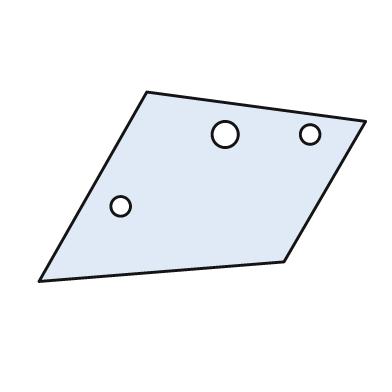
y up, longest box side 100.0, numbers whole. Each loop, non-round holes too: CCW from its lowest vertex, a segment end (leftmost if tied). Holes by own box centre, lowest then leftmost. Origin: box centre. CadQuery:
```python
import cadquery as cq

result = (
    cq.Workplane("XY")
    .moveTo(-50.0, -29.0)
    .lineTo(25.0, -23.0)
    .lineTo(50.0, 20.0)
    .lineTo(-17.0, 29.0)
    .close()
    .moveTo(-25.0, -6.0)
    .circle(3.0)
    .moveTo(7.0, 16.0)
    .circle(4.0)
    .moveTo(33.0, 16.0)
    .circle(3.0)
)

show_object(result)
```